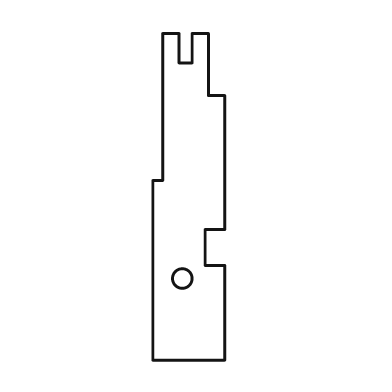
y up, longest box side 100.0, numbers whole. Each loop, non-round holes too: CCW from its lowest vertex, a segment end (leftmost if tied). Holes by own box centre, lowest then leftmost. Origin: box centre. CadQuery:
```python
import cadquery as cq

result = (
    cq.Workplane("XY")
    .moveTo(-11.0, -50.0)
    .lineTo(11.0, -50.0)
    .lineTo(11.0, -21.0)
    .lineTo(5.0, -21.0)
    .lineTo(5.0, -10.0)
    .lineTo(11.0, -10.0)
    .lineTo(11.0, 31.0)
    .lineTo(6.0, 31.0)
    .lineTo(6.0, 50.0)
    .lineTo(1.0, 50.0)
    .lineTo(1.0, 41.0)
    .lineTo(-3.0, 41.0)
    .lineTo(-3.0, 50.0)
    .lineTo(-8.0, 50.0)
    .lineTo(-8.0, 5.0)
    .lineTo(-11.0, 5.0)
    .close()
    .moveTo(-2.0, -25.0)
    .circle(3.0)
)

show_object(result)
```